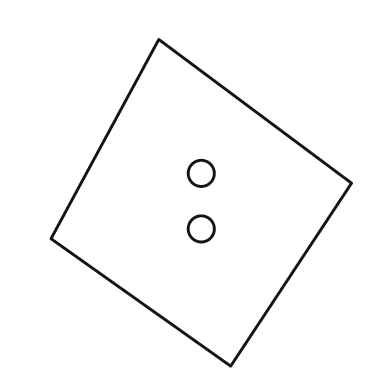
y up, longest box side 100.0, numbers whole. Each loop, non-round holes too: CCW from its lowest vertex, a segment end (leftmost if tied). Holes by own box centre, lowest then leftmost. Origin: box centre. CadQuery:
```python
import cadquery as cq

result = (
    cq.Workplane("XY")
    .moveTo(9.0, -50.0)
    .lineTo(46.0, 6.0)
    .lineTo(-13.0, 50.0)
    .lineTo(-46.0, -11.0)
    .close()
    .moveTo(0.0, -8.0)
    .circle(4.0)
    .moveTo(0.0, 9.0)
    .circle(4.0)
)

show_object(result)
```